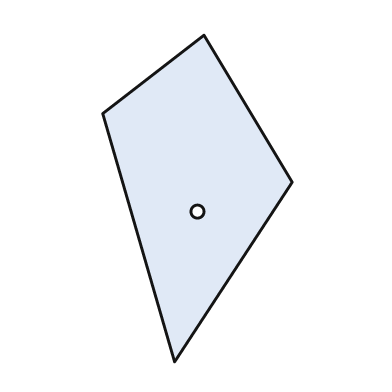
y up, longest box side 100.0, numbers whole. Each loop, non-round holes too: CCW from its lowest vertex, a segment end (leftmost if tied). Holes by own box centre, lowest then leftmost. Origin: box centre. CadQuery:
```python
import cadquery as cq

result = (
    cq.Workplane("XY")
    .moveTo(-7.0, -50.0)
    .lineTo(29.0, 5.0)
    .lineTo(2.0, 50.0)
    .lineTo(-29.0, 26.0)
    .close()
    .moveTo(0.0, -4.0)
    .circle(2.0)
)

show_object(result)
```